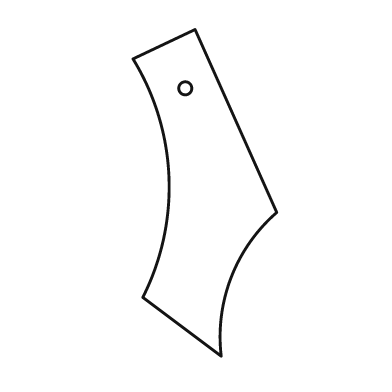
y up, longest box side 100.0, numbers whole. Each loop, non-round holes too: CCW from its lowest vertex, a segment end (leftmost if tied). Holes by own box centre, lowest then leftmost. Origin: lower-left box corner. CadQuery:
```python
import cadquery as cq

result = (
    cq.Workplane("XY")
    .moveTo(27.0, 0.0)
    .threePointArc((30.0, 24.0), (44.0, 44.0))
    .lineTo(19.0, 100.0)
    .lineTo(0.0, 91.0)
    .threePointArc((11.0, 55.0), (3.0, 18.0))
    .close()
    .moveTo(16.0, 82.0)
    .circle(2.0)
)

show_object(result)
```